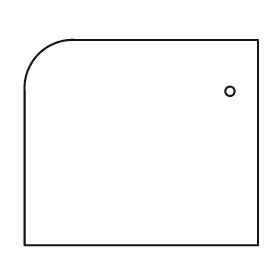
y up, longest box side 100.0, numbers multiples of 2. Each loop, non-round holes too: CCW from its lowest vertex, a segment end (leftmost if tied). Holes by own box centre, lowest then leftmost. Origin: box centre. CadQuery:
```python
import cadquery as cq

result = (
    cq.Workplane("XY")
    .moveTo(-50.0, -44.0)
    .lineTo(50.0, -44.0)
    .lineTo(50.0, 44.0)
    .lineTo(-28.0, 44.0)
    .threePointArc((-44.0, 38.0), (-50.0, 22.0))
    .close()
    .moveTo(38.0, 22.0)
    .circle(2.0)
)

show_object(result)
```